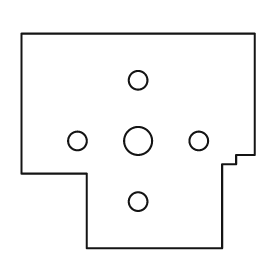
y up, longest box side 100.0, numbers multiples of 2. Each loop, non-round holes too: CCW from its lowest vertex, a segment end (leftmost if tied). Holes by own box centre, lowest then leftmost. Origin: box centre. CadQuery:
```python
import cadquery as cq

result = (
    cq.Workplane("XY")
    .moveTo(-22.0, -46.0)
    .lineTo(36.0, -46.0)
    .lineTo(36.0, -10.0)
    .lineTo(42.0, -10.0)
    .lineTo(42.0, -6.0)
    .lineTo(50.0, -6.0)
    .lineTo(50.0, 46.0)
    .lineTo(-50.0, 46.0)
    .lineTo(-50.0, -14.0)
    .lineTo(-22.0, -14.0)
    .close()
    .moveTo(0.0, -26.0)
    .circle(4.0)
    .moveTo(-26.0, 0.0)
    .circle(4.0)
    .moveTo(0.0, 0.0)
    .circle(6.0)
    .moveTo(26.0, 0.0)
    .circle(4.0)
    .moveTo(0.0, 26.0)
    .circle(4.0)
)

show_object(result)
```